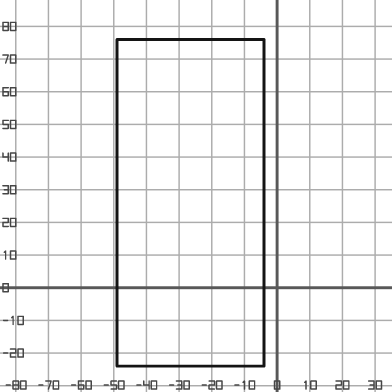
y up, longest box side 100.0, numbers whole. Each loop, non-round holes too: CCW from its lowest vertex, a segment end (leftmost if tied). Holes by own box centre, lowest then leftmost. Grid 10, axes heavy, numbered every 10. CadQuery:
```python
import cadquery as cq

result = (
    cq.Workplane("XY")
    .moveTo(-49.0, -24.0)
    .lineTo(-4.0, -24.0)
    .lineTo(-4.0, 76.0)
    .lineTo(-49.0, 76.0)
    .close()
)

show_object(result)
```